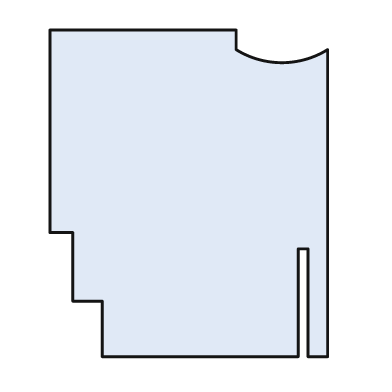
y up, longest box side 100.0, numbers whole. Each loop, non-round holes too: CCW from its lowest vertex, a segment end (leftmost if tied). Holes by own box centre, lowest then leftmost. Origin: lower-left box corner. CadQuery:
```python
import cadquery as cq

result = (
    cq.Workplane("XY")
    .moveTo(16.0, 0.0)
    .lineTo(76.0, 0.0)
    .lineTo(76.0, 33.0)
    .lineTo(79.0, 33.0)
    .lineTo(79.0, 0.0)
    .lineTo(85.0, 0.0)
    .lineTo(85.0, 94.0)
    .threePointArc((71.0, 90.0), (57.0, 94.0))
    .lineTo(57.0, 100.0)
    .lineTo(0.0, 100.0)
    .lineTo(0.0, 38.0)
    .lineTo(7.0, 38.0)
    .lineTo(7.0, 17.0)
    .lineTo(16.0, 17.0)
    .close()
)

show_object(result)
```